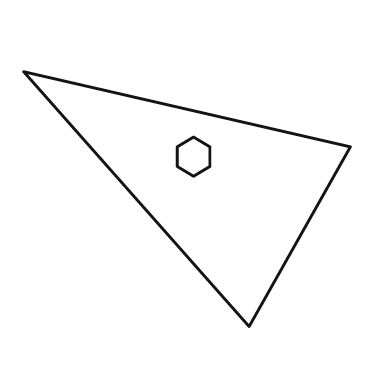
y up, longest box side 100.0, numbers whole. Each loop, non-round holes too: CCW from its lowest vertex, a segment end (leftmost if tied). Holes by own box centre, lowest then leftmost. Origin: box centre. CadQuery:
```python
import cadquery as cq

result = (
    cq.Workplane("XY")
    .moveTo(19.0, -39.0)
    .lineTo(50.0, 16.0)
    .lineTo(-50.0, 39.0)
    .close()
    .moveTo(2.0, 7.0)
    .lineTo(7.0, 10.0)
    .lineTo(7.0, 16.0)
    .lineTo(2.0, 19.0)
    .lineTo(-3.0, 16.0)
    .lineTo(-3.0, 10.0)
    .close()
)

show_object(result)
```